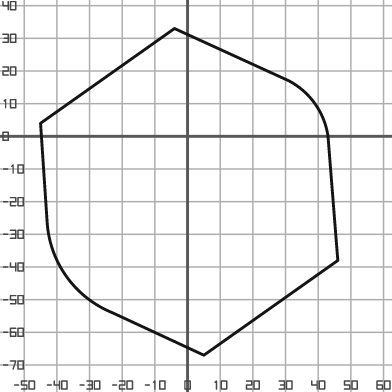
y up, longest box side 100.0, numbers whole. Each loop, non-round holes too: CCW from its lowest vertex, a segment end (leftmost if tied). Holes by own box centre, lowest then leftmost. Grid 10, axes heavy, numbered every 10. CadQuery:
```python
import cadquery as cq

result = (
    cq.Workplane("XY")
    .moveTo(5.0, -67.0)
    .lineTo(46.0, -38.0)
    .lineTo(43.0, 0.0)
    .threePointArc((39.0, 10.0), (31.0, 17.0))
    .lineTo(-4.0, 33.0)
    .lineTo(-45.0, 4.0)
    .lineTo(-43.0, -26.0)
    .threePointArc((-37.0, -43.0), (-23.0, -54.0))
    .close()
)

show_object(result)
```